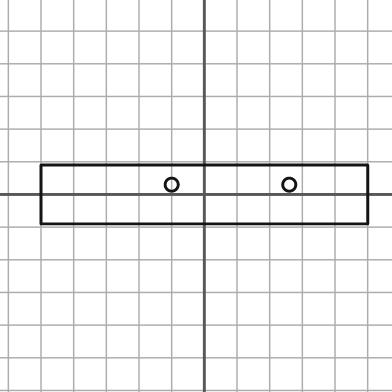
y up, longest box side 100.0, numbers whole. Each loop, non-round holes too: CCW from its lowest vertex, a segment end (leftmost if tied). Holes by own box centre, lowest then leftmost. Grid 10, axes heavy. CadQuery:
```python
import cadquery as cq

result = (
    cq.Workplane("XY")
    .moveTo(-50.0, -9.0)
    .lineTo(50.0, -9.0)
    .lineTo(50.0, 9.0)
    .lineTo(-50.0, 9.0)
    .close()
    .moveTo(-10.0, 3.0)
    .circle(2.0)
    .moveTo(26.0, 3.0)
    .circle(2.0)
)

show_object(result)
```